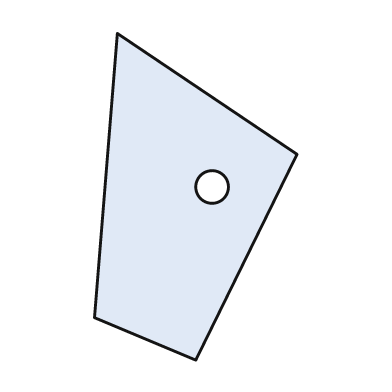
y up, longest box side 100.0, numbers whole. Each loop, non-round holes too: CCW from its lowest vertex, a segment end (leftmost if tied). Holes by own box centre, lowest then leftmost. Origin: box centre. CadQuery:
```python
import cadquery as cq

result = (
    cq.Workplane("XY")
    .moveTo(0.0, -50.0)
    .lineTo(31.0, 13.0)
    .lineTo(-24.0, 50.0)
    .lineTo(-31.0, -37.0)
    .close()
    .moveTo(5.0, 3.0)
    .circle(5.0)
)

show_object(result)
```